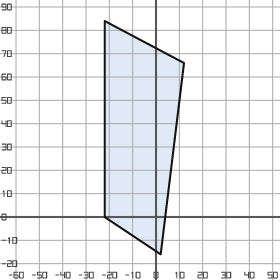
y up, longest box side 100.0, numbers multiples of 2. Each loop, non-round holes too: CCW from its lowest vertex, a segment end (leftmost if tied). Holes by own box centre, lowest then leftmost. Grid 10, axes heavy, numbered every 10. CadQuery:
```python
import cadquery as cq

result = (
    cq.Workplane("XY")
    .moveTo(2.0, -16.0)
    .lineTo(12.0, 66.0)
    .lineTo(-22.0, 84.0)
    .lineTo(-22.0, 0.0)
    .close()
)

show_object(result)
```